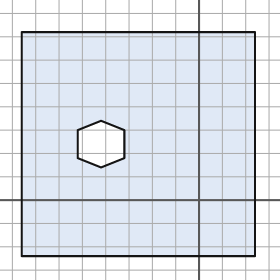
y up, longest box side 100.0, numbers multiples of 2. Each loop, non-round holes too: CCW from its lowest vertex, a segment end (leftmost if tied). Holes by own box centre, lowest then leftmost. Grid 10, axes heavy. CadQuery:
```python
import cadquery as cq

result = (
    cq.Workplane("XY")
    .moveTo(-76.0, -24.0)
    .lineTo(24.0, -24.0)
    .lineTo(24.0, 72.0)
    .lineTo(-76.0, 72.0)
    .close()
    .moveTo(-42.0, 14.0)
    .lineTo(-32.0, 18.0)
    .lineTo(-32.0, 30.0)
    .lineTo(-42.0, 34.0)
    .lineTo(-52.0, 30.0)
    .lineTo(-52.0, 18.0)
    .close()
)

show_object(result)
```